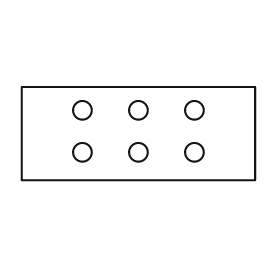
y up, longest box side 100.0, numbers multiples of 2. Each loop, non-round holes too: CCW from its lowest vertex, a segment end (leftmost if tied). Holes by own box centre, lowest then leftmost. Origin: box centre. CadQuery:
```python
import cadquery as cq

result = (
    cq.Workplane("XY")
    .moveTo(-50.0, -20.0)
    .lineTo(50.0, -20.0)
    .lineTo(50.0, 20.0)
    .lineTo(-50.0, 20.0)
    .close()
    .moveTo(-24.0, -8.0)
    .circle(4.0)
    .moveTo(0.0, -8.0)
    .circle(4.0)
    .moveTo(24.0, -8.0)
    .circle(4.0)
    .moveTo(-24.0, 10.0)
    .circle(4.0)
    .moveTo(0.0, 10.0)
    .circle(4.0)
    .moveTo(24.0, 10.0)
    .circle(4.0)
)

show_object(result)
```